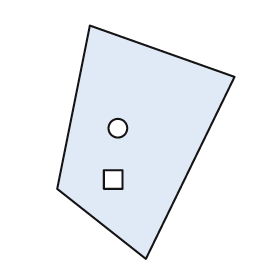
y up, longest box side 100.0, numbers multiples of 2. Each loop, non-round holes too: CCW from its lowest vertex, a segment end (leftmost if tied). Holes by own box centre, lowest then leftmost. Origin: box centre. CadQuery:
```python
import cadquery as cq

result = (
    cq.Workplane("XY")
    .moveTo(0.0, -50.0)
    .lineTo(38.0, 28.0)
    .lineTo(-24.0, 50.0)
    .lineTo(-38.0, -20.0)
    .close()
    .moveTo(-18.0, -20.0)
    .lineTo(-10.0, -20.0)
    .lineTo(-10.0, -12.0)
    .lineTo(-18.0, -12.0)
    .close()
    .moveTo(-12.0, 6.0)
    .circle(4.0)
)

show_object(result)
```